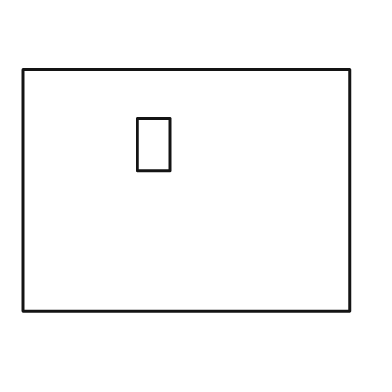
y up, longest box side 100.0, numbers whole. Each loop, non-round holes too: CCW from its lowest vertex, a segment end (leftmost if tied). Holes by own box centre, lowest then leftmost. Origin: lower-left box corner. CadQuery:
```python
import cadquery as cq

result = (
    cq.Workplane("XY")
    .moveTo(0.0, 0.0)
    .lineTo(100.0, 0.0)
    .lineTo(100.0, 74.0)
    .lineTo(0.0, 74.0)
    .close()
    .moveTo(35.0, 43.0)
    .lineTo(45.0, 43.0)
    .lineTo(45.0, 59.0)
    .lineTo(35.0, 59.0)
    .close()
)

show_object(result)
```